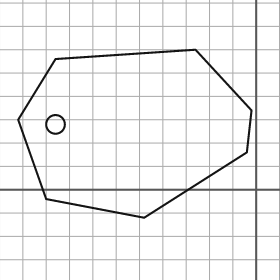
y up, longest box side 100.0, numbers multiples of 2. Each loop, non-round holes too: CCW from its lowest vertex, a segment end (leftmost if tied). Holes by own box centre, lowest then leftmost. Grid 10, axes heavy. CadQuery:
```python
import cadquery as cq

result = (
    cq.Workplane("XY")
    .moveTo(-48.0, -12.0)
    .lineTo(-4.0, 16.0)
    .lineTo(-2.0, 34.0)
    .lineTo(-26.0, 60.0)
    .lineTo(-86.0, 56.0)
    .lineTo(-102.0, 30.0)
    .lineTo(-90.0, -4.0)
    .close()
    .moveTo(-86.0, 28.0)
    .circle(4.0)
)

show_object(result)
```